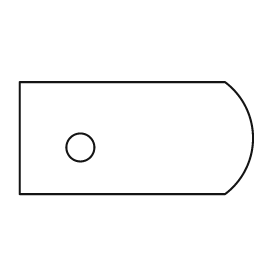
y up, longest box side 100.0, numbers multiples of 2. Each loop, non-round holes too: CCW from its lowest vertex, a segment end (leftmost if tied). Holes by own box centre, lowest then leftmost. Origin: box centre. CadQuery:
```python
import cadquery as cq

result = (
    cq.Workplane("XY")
    .moveTo(-50.0, -24.0)
    .lineTo(38.0, -24.0)
    .threePointArc((50.0, 0.0), (38.0, 24.0))
    .lineTo(-50.0, 24.0)
    .close()
    .moveTo(-24.0, -4.0)
    .circle(6.0)
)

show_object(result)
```